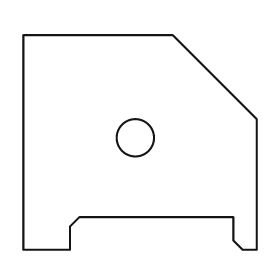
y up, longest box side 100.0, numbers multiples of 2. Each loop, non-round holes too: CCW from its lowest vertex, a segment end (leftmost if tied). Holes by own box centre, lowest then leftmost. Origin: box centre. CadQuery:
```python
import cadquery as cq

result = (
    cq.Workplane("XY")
    .moveTo(-50.0, -46.0)
    .lineTo(-30.0, -46.0)
    .lineTo(-30.0, -36.0)
    .lineTo(-26.0, -32.0)
    .lineTo(40.0, -32.0)
    .lineTo(40.0, -42.0)
    .lineTo(44.0, -46.0)
    .lineTo(50.0, -46.0)
    .lineTo(50.0, 10.0)
    .lineTo(14.0, 46.0)
    .lineTo(-50.0, 46.0)
    .close()
    .moveTo(-2.0, 2.0)
    .circle(8.0)
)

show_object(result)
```